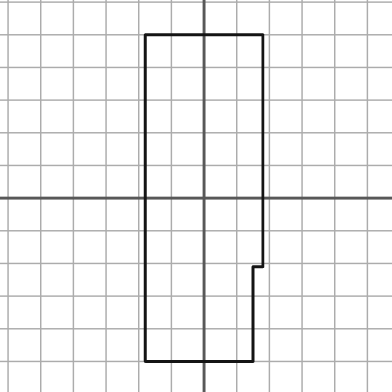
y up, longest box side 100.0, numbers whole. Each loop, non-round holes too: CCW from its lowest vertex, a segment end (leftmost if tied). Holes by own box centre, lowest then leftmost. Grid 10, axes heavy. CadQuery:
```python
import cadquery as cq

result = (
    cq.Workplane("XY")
    .moveTo(-18.0, -50.0)
    .lineTo(15.0, -50.0)
    .lineTo(15.0, -21.0)
    .lineTo(18.0, -21.0)
    .lineTo(18.0, 50.0)
    .lineTo(-18.0, 50.0)
    .close()
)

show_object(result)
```